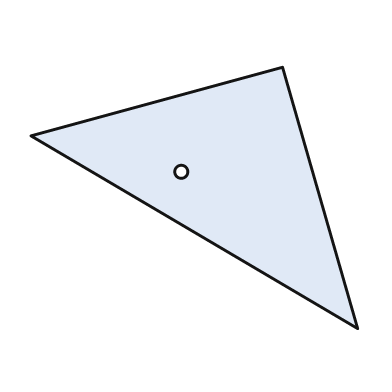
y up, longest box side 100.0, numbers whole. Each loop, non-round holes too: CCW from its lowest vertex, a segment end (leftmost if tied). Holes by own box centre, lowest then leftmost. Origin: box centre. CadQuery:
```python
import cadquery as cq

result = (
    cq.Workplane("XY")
    .moveTo(50.0, -40.0)
    .lineTo(27.0, 40.0)
    .lineTo(-50.0, 19.0)
    .close()
    .moveTo(-4.0, 8.0)
    .circle(2.0)
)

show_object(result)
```